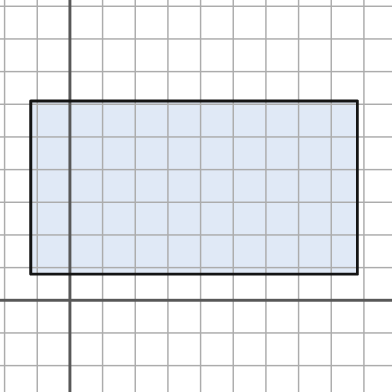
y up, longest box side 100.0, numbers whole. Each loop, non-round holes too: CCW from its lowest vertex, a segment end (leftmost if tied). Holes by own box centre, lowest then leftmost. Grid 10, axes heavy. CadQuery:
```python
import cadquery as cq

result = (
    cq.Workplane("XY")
    .moveTo(-12.0, 8.0)
    .lineTo(88.0, 8.0)
    .lineTo(88.0, 61.0)
    .lineTo(-12.0, 61.0)
    .close()
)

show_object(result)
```